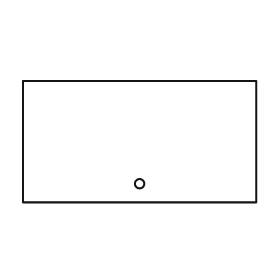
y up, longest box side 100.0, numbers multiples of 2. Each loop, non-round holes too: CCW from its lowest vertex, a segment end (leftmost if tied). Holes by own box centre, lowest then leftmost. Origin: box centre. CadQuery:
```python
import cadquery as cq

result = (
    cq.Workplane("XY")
    .moveTo(-50.0, -26.0)
    .lineTo(50.0, -26.0)
    .lineTo(50.0, 26.0)
    .lineTo(-50.0, 26.0)
    .close()
    .moveTo(0.0, -18.0)
    .circle(2.0)
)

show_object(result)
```